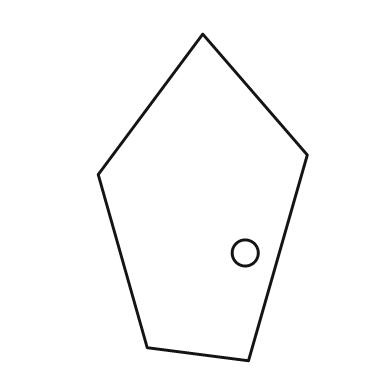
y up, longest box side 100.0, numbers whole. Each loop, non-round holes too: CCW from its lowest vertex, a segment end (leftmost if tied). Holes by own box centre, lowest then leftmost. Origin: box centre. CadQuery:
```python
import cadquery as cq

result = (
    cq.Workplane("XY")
    .moveTo(14.0, -50.0)
    .lineTo(32.0, 13.0)
    .lineTo(0.0, 50.0)
    .lineTo(-32.0, 7.0)
    .lineTo(-17.0, -46.0)
    .close()
    .moveTo(13.0, -17.0)
    .circle(4.0)
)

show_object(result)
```